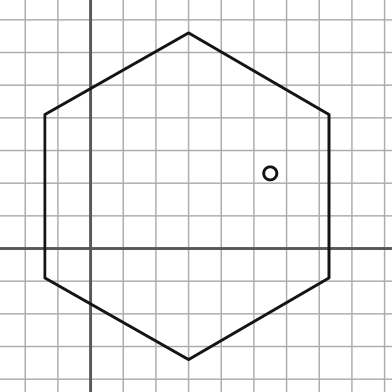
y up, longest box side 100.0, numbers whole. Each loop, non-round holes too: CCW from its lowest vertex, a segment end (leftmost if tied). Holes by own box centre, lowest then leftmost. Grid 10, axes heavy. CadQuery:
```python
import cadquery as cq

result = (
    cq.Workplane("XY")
    .moveTo(30.0, -34.0)
    .lineTo(73.0, -9.0)
    .lineTo(73.0, 41.0)
    .lineTo(30.0, 66.0)
    .lineTo(-14.0, 41.0)
    .lineTo(-14.0, -9.0)
    .close()
    .moveTo(55.0, 23.0)
    .circle(2.0)
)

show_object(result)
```